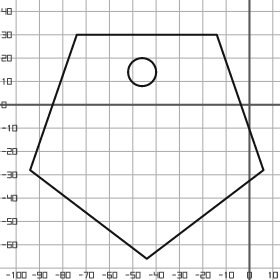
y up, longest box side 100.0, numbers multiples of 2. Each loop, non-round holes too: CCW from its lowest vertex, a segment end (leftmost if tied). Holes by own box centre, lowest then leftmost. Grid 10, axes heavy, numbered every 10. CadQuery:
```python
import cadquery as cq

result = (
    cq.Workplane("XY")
    .moveTo(-44.0, -66.0)
    .lineTo(6.0, -28.0)
    .lineTo(-14.0, 30.0)
    .lineTo(-74.0, 30.0)
    .lineTo(-94.0, -28.0)
    .close()
    .moveTo(-46.0, 14.0)
    .circle(6.0)
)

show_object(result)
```